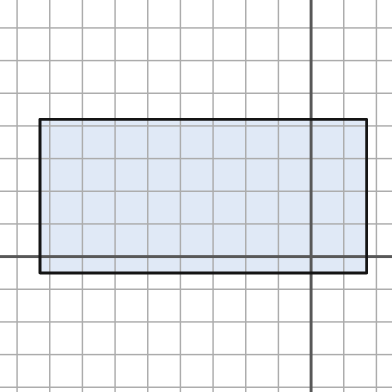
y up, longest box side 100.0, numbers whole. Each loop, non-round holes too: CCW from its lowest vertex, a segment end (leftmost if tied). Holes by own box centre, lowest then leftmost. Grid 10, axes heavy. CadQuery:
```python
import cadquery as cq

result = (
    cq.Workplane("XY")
    .moveTo(-83.0, -5.0)
    .lineTo(17.0, -5.0)
    .lineTo(17.0, 42.0)
    .lineTo(-83.0, 42.0)
    .close()
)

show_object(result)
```